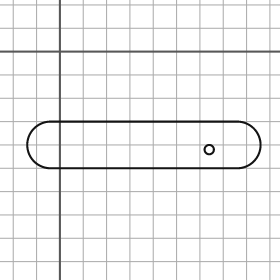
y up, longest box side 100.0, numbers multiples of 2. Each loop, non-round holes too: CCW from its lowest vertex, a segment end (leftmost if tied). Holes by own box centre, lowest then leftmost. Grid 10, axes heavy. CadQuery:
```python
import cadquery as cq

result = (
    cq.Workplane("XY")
    .moveTo(-4.0, -50.0)
    .lineTo(76.0, -50.0)
    .threePointArc((86.0, -40.0), (76.0, -30.0))
    .lineTo(-4.0, -30.0)
    .threePointArc((-14.0, -40.0), (-4.0, -50.0))
    .close()
    .moveTo(64.0, -42.0)
    .circle(2.0)
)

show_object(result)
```